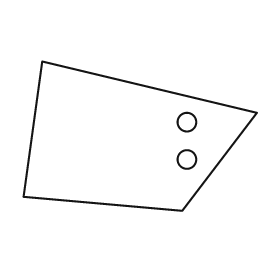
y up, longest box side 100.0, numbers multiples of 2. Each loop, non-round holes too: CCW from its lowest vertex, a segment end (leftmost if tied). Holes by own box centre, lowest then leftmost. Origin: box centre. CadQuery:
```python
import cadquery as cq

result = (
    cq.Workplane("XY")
    .moveTo(18.0, -32.0)
    .lineTo(50.0, 10.0)
    .lineTo(-42.0, 32.0)
    .lineTo(-50.0, -26.0)
    .close()
    .moveTo(20.0, -10.0)
    .circle(4.0)
    .moveTo(20.0, 6.0)
    .circle(4.0)
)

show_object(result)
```